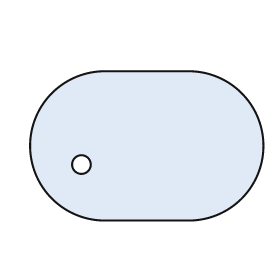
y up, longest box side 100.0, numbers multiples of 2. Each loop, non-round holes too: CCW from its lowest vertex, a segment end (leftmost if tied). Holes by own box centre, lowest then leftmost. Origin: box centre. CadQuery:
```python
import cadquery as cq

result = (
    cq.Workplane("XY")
    .moveTo(-18.0, -32.0)
    .lineTo(18.0, -32.0)
    .threePointArc((50.0, 0.0), (18.0, 32.0))
    .lineTo(-18.0, 32.0)
    .threePointArc((-50.0, 0.0), (-18.0, -32.0))
    .close()
    .moveTo(-28.0, -8.0)
    .circle(4.0)
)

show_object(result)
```